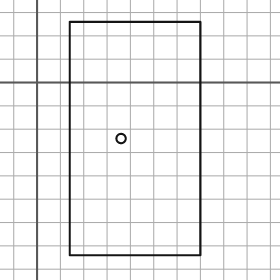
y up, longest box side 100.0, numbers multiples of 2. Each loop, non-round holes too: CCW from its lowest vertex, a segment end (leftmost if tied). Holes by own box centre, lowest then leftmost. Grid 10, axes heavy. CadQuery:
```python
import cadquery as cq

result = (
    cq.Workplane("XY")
    .moveTo(14.0, -74.0)
    .lineTo(70.0, -74.0)
    .lineTo(70.0, 26.0)
    .lineTo(14.0, 26.0)
    .close()
    .moveTo(36.0, -24.0)
    .circle(2.0)
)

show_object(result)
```